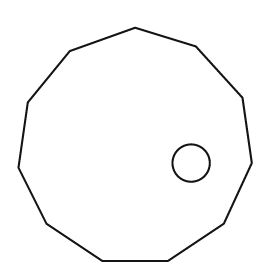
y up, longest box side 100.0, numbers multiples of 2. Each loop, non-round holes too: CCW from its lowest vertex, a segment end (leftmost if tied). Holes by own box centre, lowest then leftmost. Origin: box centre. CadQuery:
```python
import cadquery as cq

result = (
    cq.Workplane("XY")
    .moveTo(-14.0, -50.0)
    .lineTo(14.0, -50.0)
    .lineTo(38.0, -34.0)
    .lineTo(50.0, -8.0)
    .lineTo(46.0, 20.0)
    .lineTo(26.0, 42.0)
    .lineTo(0.0, 50.0)
    .lineTo(-28.0, 40.0)
    .lineTo(-46.0, 18.0)
    .lineTo(-50.0, -10.0)
    .lineTo(-38.0, -34.0)
    .close()
    .moveTo(24.0, -8.0)
    .circle(8.0)
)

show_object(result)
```